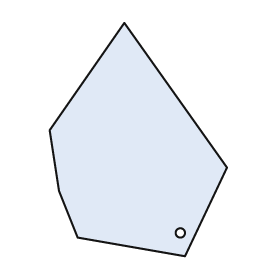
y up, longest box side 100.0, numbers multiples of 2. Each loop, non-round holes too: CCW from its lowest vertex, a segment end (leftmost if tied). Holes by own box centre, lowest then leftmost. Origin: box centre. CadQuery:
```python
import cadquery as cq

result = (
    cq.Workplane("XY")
    .moveTo(20.0, -50.0)
    .lineTo(38.0, -12.0)
    .lineTo(-6.0, 50.0)
    .lineTo(-38.0, 4.0)
    .lineTo(-34.0, -22.0)
    .lineTo(-26.0, -42.0)
    .close()
    .moveTo(18.0, -40.0)
    .circle(2.0)
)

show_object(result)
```